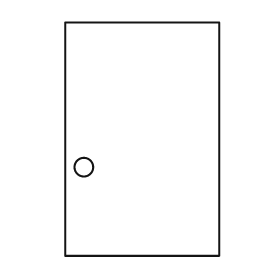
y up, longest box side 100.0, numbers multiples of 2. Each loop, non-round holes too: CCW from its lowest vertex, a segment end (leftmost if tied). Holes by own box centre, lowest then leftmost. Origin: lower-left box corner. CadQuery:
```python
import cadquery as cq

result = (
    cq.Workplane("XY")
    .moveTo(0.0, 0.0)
    .lineTo(66.0, 0.0)
    .lineTo(66.0, 100.0)
    .lineTo(0.0, 100.0)
    .close()
    .moveTo(8.0, 38.0)
    .circle(4.0)
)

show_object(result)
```